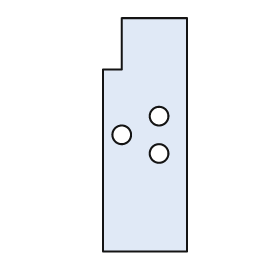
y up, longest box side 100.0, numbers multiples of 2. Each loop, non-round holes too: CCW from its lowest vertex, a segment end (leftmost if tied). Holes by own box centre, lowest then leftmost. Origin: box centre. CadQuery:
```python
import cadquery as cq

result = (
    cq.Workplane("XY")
    .moveTo(-18.0, -50.0)
    .lineTo(18.0, -50.0)
    .lineTo(18.0, 50.0)
    .lineTo(-10.0, 50.0)
    .lineTo(-10.0, 28.0)
    .lineTo(-18.0, 28.0)
    .close()
    .moveTo(6.0, -8.0)
    .circle(4.0)
    .moveTo(-10.0, 0.0)
    .circle(4.0)
    .moveTo(6.0, 8.0)
    .circle(4.0)
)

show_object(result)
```